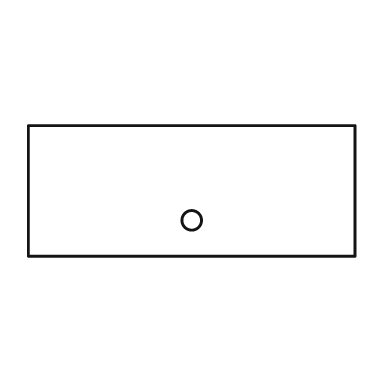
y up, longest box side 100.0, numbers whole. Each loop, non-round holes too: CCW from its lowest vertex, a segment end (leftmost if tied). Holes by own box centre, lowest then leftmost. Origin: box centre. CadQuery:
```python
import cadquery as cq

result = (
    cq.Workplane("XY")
    .moveTo(-50.0, -20.0)
    .lineTo(50.0, -20.0)
    .lineTo(50.0, 20.0)
    .lineTo(-50.0, 20.0)
    .close()
    .moveTo(0.0, -9.0)
    .circle(3.0)
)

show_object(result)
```